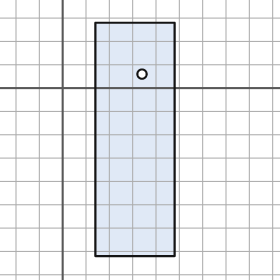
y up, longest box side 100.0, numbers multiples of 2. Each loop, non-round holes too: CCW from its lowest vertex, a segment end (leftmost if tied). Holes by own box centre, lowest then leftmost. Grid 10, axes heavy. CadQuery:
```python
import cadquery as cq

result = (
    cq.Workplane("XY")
    .moveTo(14.0, -72.0)
    .lineTo(48.0, -72.0)
    .lineTo(48.0, 28.0)
    .lineTo(14.0, 28.0)
    .close()
    .moveTo(34.0, 6.0)
    .circle(2.0)
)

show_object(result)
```